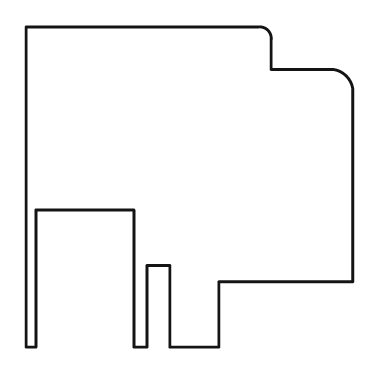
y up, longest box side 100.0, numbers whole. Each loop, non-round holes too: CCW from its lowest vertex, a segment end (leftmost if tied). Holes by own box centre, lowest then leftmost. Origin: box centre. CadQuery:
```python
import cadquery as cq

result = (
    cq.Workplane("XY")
    .moveTo(-50.0, -49.0)
    .lineTo(-47.0, -49.0)
    .lineTo(-47.0, -7.0)
    .lineTo(-17.0, -7.0)
    .lineTo(-17.0, -49.0)
    .lineTo(-13.0, -49.0)
    .lineTo(-13.0, -24.0)
    .lineTo(-6.0, -24.0)
    .lineTo(-6.0, -49.0)
    .lineTo(9.0, -49.0)
    .lineTo(9.0, -29.0)
    .lineTo(50.0, -29.0)
    .lineTo(50.0, 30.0)
    .threePointArc((48.0, 34.0), (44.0, 36.0))
    .lineTo(25.0, 36.0)
    .lineTo(25.0, 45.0)
    .threePointArc((24.0, 48.0), (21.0, 49.0))
    .lineTo(-50.0, 49.0)
    .close()
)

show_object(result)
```